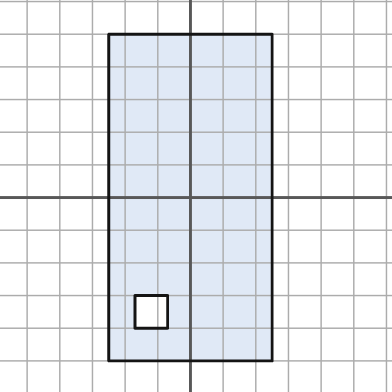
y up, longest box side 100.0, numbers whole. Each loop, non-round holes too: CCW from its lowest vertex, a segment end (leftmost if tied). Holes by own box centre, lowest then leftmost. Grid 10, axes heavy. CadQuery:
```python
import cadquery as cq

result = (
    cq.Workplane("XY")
    .moveTo(-25.0, -50.0)
    .lineTo(25.0, -50.0)
    .lineTo(25.0, 50.0)
    .lineTo(-25.0, 50.0)
    .close()
    .moveTo(-17.0, -40.0)
    .lineTo(-7.0, -40.0)
    .lineTo(-7.0, -30.0)
    .lineTo(-17.0, -30.0)
    .close()
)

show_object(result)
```